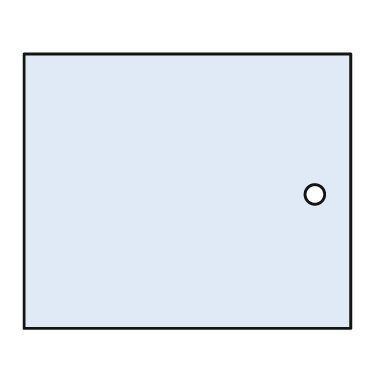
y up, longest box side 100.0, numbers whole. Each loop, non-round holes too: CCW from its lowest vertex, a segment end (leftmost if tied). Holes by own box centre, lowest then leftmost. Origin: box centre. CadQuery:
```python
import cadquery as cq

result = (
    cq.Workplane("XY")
    .moveTo(-50.0, -42.0)
    .lineTo(50.0, -42.0)
    .lineTo(50.0, 42.0)
    .lineTo(-50.0, 42.0)
    .close()
    .moveTo(39.0, -1.0)
    .circle(3.0)
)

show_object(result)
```